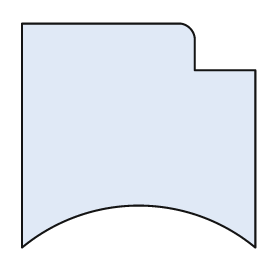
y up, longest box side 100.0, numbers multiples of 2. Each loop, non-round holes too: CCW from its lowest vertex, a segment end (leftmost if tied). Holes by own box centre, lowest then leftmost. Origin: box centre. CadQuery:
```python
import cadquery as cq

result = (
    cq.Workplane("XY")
    .moveTo(-50.0, -48.0)
    .threePointArc((0.0, -30.0), (50.0, -48.0))
    .lineTo(50.0, 28.0)
    .lineTo(24.0, 28.0)
    .lineTo(24.0, 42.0)
    .threePointArc((22.0, 46.0), (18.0, 48.0))
    .lineTo(-50.0, 48.0)
    .close()
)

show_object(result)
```